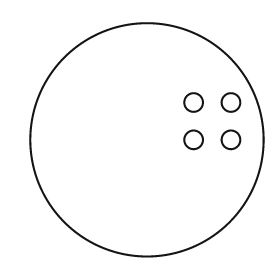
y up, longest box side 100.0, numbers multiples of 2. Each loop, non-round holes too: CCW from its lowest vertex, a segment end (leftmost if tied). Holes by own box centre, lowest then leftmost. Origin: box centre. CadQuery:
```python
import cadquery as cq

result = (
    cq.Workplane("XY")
    .moveTo(0.0, 0.0)
    .circle(50.0)
    .moveTo(20.0, 0.0)
    .circle(4.0)
    .moveTo(36.0, 0.0)
    .circle(4.0)
    .moveTo(20.0, 16.0)
    .circle(4.0)
    .moveTo(36.0, 16.0)
    .circle(4.0)
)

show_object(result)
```